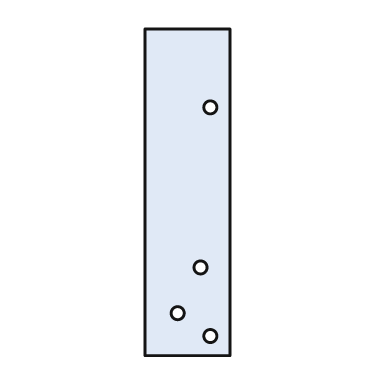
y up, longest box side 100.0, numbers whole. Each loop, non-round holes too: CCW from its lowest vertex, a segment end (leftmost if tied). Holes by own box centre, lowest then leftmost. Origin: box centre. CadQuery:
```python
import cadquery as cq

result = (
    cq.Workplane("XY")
    .moveTo(-13.0, -50.0)
    .lineTo(13.0, -50.0)
    .lineTo(13.0, 50.0)
    .lineTo(-13.0, 50.0)
    .close()
    .moveTo(7.0, -44.0)
    .circle(2.0)
    .moveTo(-3.0, -37.0)
    .circle(2.0)
    .moveTo(4.0, -23.0)
    .circle(2.0)
    .moveTo(7.0, 26.0)
    .circle(2.0)
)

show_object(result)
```